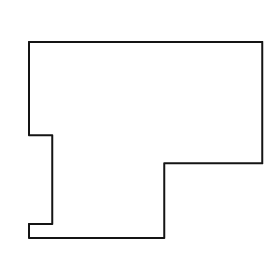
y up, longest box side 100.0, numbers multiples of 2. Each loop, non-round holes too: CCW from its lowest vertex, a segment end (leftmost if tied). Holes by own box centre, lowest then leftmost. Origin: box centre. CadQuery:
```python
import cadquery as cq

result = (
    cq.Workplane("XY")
    .moveTo(-50.0, -42.0)
    .lineTo(8.0, -42.0)
    .lineTo(8.0, -10.0)
    .lineTo(50.0, -10.0)
    .lineTo(50.0, 42.0)
    .lineTo(-50.0, 42.0)
    .lineTo(-50.0, 2.0)
    .lineTo(-40.0, 2.0)
    .lineTo(-40.0, -36.0)
    .lineTo(-50.0, -36.0)
    .close()
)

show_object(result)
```